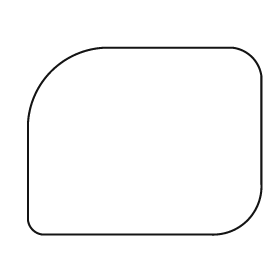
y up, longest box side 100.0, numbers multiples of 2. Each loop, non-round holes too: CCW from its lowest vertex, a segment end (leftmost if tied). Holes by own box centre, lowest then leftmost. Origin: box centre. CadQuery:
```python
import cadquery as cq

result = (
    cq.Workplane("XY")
    .moveTo(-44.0, -40.0)
    .lineTo(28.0, -40.0)
    .threePointArc((44.0, -34.0), (50.0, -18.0))
    .lineTo(50.0, 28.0)
    .threePointArc((46.0, 36.0), (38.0, 40.0))
    .lineTo(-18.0, 40.0)
    .threePointArc((-40.0, 30.0), (-50.0, 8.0))
    .lineTo(-50.0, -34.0)
    .threePointArc((-48.0, -38.0), (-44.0, -40.0))
    .close()
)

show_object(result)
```